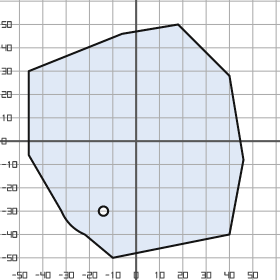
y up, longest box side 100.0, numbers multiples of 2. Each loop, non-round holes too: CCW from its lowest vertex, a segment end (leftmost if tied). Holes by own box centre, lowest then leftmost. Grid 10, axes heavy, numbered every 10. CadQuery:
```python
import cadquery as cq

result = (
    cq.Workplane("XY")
    .moveTo(-10.0, -50.0)
    .lineTo(40.0, -40.0)
    .lineTo(46.0, -8.0)
    .lineTo(40.0, 28.0)
    .lineTo(18.0, 50.0)
    .lineTo(-6.0, 46.0)
    .lineTo(-46.0, 30.0)
    .lineTo(-46.0, -6.0)
    .lineTo(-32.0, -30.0)
    .threePointArc((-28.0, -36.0), (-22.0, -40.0))
    .close()
    .moveTo(-14.0, -30.0)
    .circle(2.0)
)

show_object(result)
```